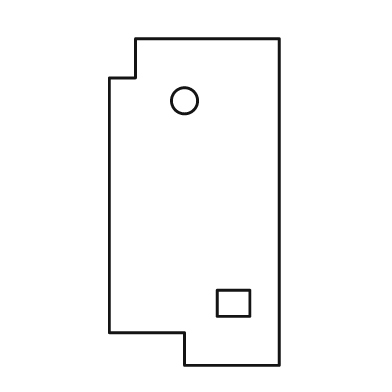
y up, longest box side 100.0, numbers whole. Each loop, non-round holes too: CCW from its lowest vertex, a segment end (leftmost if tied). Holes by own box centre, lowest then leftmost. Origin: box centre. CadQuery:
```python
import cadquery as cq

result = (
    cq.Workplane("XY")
    .moveTo(-3.0, -50.0)
    .lineTo(26.0, -50.0)
    .lineTo(26.0, 50.0)
    .lineTo(-18.0, 50.0)
    .lineTo(-18.0, 38.0)
    .lineTo(-26.0, 38.0)
    .lineTo(-26.0, -40.0)
    .lineTo(-3.0, -40.0)
    .close()
    .moveTo(7.0, -35.0)
    .lineTo(17.0, -35.0)
    .lineTo(17.0, -27.0)
    .lineTo(7.0, -27.0)
    .close()
    .moveTo(-3.0, 31.0)
    .circle(4.0)
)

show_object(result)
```